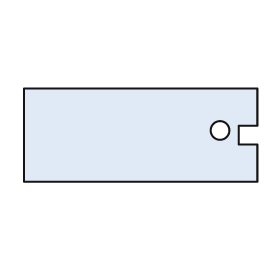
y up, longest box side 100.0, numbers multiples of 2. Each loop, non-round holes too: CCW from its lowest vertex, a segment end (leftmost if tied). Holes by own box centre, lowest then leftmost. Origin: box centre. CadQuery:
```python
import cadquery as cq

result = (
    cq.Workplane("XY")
    .moveTo(-50.0, -20.0)
    .lineTo(50.0, -20.0)
    .lineTo(50.0, -4.0)
    .lineTo(42.0, -4.0)
    .lineTo(42.0, 4.0)
    .lineTo(50.0, 4.0)
    .lineTo(50.0, 20.0)
    .lineTo(-50.0, 20.0)
    .close()
    .moveTo(34.0, 2.0)
    .circle(4.0)
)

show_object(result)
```